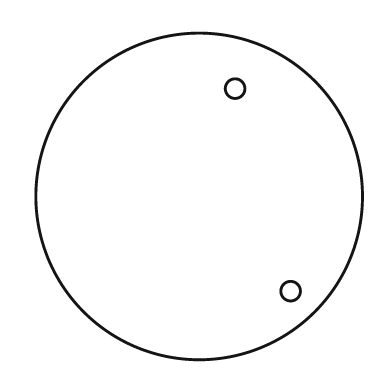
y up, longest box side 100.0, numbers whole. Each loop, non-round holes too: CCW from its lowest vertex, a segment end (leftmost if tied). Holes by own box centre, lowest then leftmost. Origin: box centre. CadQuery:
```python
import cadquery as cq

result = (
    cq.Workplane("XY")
    .moveTo(0.0, 0.0)
    .circle(50.0)
    .moveTo(28.0, -29.0)
    .circle(3.0)
    .moveTo(11.0, 33.0)
    .circle(3.0)
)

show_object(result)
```